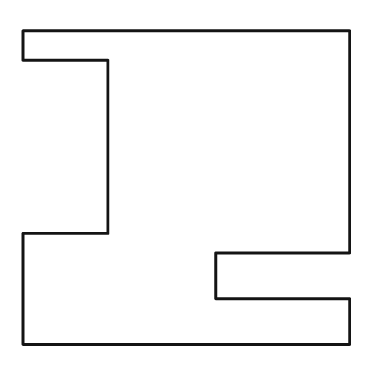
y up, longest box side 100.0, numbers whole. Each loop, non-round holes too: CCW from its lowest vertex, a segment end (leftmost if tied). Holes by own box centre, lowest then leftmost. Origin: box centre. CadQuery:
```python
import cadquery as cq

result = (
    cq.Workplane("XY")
    .moveTo(-50.0, -48.0)
    .lineTo(50.0, -48.0)
    .lineTo(50.0, -34.0)
    .lineTo(9.0, -34.0)
    .lineTo(9.0, -20.0)
    .lineTo(50.0, -20.0)
    .lineTo(50.0, 48.0)
    .lineTo(-50.0, 48.0)
    .lineTo(-50.0, 39.0)
    .lineTo(-24.0, 39.0)
    .lineTo(-24.0, -14.0)
    .lineTo(-50.0, -14.0)
    .close()
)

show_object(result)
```